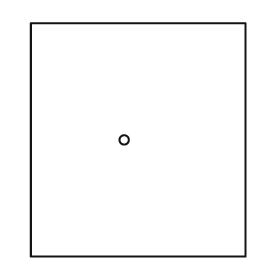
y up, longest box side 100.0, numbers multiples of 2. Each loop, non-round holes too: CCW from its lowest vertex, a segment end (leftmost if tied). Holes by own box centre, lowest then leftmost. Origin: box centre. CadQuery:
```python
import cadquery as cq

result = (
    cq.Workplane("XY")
    .moveTo(-46.0, -50.0)
    .lineTo(46.0, -50.0)
    .lineTo(46.0, 50.0)
    .lineTo(-46.0, 50.0)
    .close()
    .moveTo(-6.0, 0.0)
    .circle(2.0)
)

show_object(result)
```